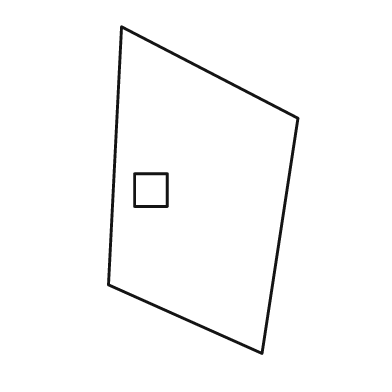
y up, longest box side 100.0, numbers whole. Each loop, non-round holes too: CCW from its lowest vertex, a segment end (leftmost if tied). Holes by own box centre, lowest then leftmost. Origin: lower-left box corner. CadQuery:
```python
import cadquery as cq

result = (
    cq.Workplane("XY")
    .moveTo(47.0, 0.0)
    .lineTo(58.0, 72.0)
    .lineTo(4.0, 100.0)
    .lineTo(0.0, 21.0)
    .close()
    .moveTo(8.0, 45.0)
    .lineTo(18.0, 45.0)
    .lineTo(18.0, 55.0)
    .lineTo(8.0, 55.0)
    .close()
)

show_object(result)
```